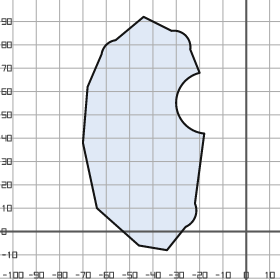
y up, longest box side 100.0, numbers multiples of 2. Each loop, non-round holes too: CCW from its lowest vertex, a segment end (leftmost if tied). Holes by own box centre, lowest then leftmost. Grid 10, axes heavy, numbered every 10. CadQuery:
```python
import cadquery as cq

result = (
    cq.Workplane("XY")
    .moveTo(-34.0, -8.0)
    .lineTo(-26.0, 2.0)
    .threePointArc((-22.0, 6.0), (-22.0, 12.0))
    .lineTo(-18.0, 42.0)
    .threePointArc((-30.0, 54.0), (-20.0, 68.0))
    .lineTo(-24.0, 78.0)
    .threePointArc((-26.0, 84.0), (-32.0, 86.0))
    .lineTo(-44.0, 92.0)
    .lineTo(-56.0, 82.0)
    .threePointArc((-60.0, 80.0), (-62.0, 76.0))
    .lineTo(-68.0, 62.0)
    .lineTo(-70.0, 38.0)
    .lineTo(-64.0, 10.0)
    .lineTo(-46.0, -6.0)
    .close()
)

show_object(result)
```